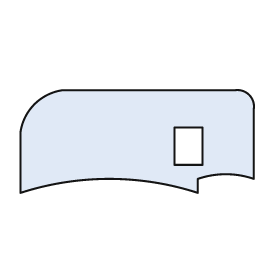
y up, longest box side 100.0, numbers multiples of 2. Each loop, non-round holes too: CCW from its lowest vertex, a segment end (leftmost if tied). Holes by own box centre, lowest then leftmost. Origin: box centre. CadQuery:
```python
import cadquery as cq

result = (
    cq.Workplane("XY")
    .moveTo(-50.0, -22.0)
    .threePointArc((-12.0, -16.0), (26.0, -22.0))
    .lineTo(26.0, -16.0)
    .threePointArc((38.0, -14.0), (50.0, -16.0))
    .lineTo(50.0, 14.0)
    .threePointArc((48.0, 20.0), (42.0, 22.0))
    .lineTo(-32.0, 22.0)
    .threePointArc((-44.0, 16.0), (-50.0, 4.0))
    .close()
    .moveTo(16.0, -10.0)
    .lineTo(28.0, -10.0)
    .lineTo(28.0, 6.0)
    .lineTo(16.0, 6.0)
    .close()
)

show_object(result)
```